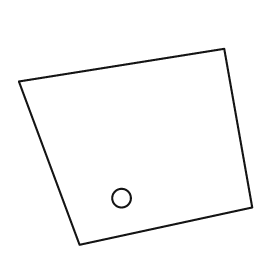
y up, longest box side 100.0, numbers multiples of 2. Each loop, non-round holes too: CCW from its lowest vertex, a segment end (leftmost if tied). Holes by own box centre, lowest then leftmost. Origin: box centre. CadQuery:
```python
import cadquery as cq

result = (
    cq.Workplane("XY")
    .moveTo(-24.0, -42.0)
    .lineTo(50.0, -26.0)
    .lineTo(38.0, 42.0)
    .lineTo(-50.0, 28.0)
    .close()
    .moveTo(-6.0, -22.0)
    .circle(4.0)
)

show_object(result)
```